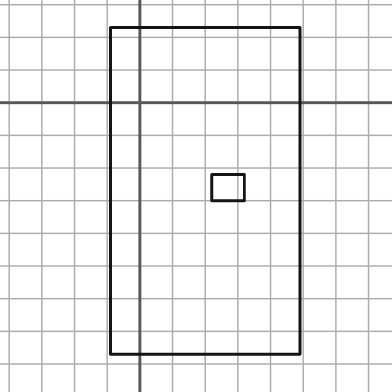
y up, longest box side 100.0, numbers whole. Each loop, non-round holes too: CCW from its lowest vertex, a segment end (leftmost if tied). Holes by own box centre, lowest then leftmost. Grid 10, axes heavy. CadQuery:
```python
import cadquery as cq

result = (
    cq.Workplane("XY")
    .moveTo(-9.0, -77.0)
    .lineTo(49.0, -77.0)
    .lineTo(49.0, 23.0)
    .lineTo(-9.0, 23.0)
    .close()
    .moveTo(22.0, -30.0)
    .lineTo(32.0, -30.0)
    .lineTo(32.0, -22.0)
    .lineTo(22.0, -22.0)
    .close()
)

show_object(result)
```